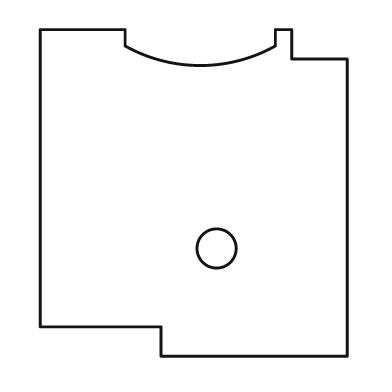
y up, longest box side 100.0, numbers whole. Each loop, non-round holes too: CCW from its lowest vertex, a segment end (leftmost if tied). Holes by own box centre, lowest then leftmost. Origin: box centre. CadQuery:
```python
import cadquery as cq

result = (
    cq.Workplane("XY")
    .moveTo(-10.0, -50.0)
    .lineTo(47.0, -50.0)
    .lineTo(47.0, 41.0)
    .lineTo(30.0, 41.0)
    .lineTo(30.0, 50.0)
    .lineTo(25.0, 50.0)
    .lineTo(25.0, 45.0)
    .threePointArc((2.0, 39.0), (-21.0, 45.0))
    .lineTo(-21.0, 50.0)
    .lineTo(-47.0, 50.0)
    .lineTo(-47.0, -41.0)
    .lineTo(-10.0, -41.0)
    .close()
    .moveTo(7.0, -17.0)
    .circle(6.0)
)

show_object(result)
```